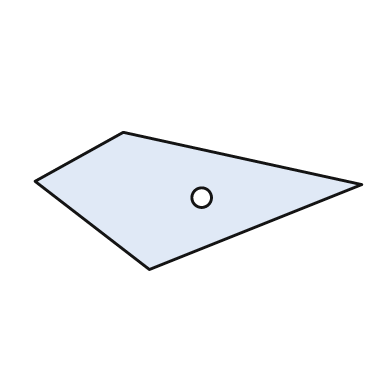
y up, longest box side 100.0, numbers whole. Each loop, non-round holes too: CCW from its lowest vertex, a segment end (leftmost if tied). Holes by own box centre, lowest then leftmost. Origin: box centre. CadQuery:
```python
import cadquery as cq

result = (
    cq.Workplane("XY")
    .moveTo(-15.0, -21.0)
    .lineTo(50.0, 5.0)
    .lineTo(-23.0, 21.0)
    .lineTo(-50.0, 6.0)
    .close()
    .moveTo(1.0, 1.0)
    .circle(3.0)
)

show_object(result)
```